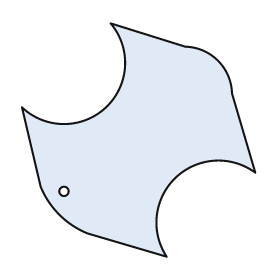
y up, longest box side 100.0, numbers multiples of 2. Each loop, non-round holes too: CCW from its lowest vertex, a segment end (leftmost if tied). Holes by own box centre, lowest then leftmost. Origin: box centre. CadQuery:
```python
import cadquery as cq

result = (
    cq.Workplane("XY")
    .moveTo(12.0, -50.0)
    .threePointArc((16.0, -16.0), (50.0, -14.0))
    .lineTo(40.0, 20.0)
    .threePointArc((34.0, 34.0), (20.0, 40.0))
    .lineTo(-12.0, 50.0)
    .threePointArc((-14.0, 14.0), (-50.0, 14.0))
    .lineTo(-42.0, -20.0)
    .threePointArc((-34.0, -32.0), (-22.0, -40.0))
    .close()
    .moveTo(-32.0, -22.0)
    .circle(2.0)
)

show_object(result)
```